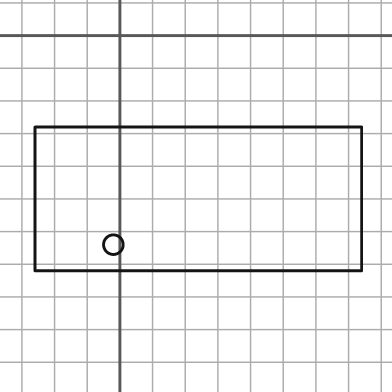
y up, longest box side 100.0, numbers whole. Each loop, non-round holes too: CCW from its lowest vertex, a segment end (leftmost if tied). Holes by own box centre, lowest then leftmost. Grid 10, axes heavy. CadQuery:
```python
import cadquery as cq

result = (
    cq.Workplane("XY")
    .moveTo(-26.0, -72.0)
    .lineTo(74.0, -72.0)
    .lineTo(74.0, -28.0)
    .lineTo(-26.0, -28.0)
    .close()
    .moveTo(-2.0, -64.0)
    .circle(3.0)
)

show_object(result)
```